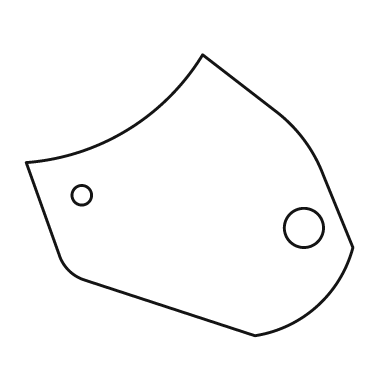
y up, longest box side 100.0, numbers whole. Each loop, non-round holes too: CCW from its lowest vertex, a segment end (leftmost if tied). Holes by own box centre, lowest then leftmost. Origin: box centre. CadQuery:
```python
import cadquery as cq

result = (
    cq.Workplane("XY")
    .moveTo(20.0, -43.0)
    .threePointArc((39.0, -34.0), (50.0, -16.0))
    .lineTo(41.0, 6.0)
    .threePointArc((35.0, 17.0), (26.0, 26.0))
    .lineTo(4.0, 43.0)
    .threePointArc((-19.0, 20.0), (-50.0, 10.0))
    .lineTo(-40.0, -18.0)
    .threePointArc((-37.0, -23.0), (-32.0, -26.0))
    .close()
    .moveTo(35.0, -10.0)
    .circle(6.0)
    .moveTo(-33.0, 0.0)
    .circle(3.0)
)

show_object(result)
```